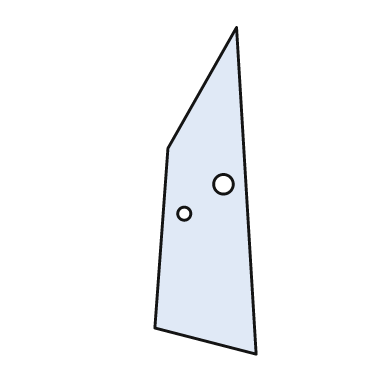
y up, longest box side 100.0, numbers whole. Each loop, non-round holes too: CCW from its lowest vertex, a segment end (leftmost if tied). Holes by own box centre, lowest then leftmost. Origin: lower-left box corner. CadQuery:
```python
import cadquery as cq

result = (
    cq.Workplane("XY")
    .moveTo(31.0, 0.0)
    .lineTo(25.0, 100.0)
    .lineTo(4.0, 63.0)
    .lineTo(0.0, 8.0)
    .close()
    .moveTo(9.0, 43.0)
    .circle(2.0)
    .moveTo(21.0, 52.0)
    .circle(3.0)
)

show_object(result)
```